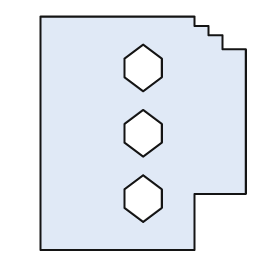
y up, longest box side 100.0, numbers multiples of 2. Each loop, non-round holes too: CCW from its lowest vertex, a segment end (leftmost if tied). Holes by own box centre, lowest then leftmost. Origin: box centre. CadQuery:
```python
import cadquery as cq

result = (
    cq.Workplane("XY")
    .moveTo(-44.0, -50.0)
    .lineTo(22.0, -50.0)
    .lineTo(22.0, -26.0)
    .lineTo(44.0, -26.0)
    .lineTo(44.0, 36.0)
    .lineTo(34.0, 36.0)
    .lineTo(34.0, 42.0)
    .lineTo(28.0, 42.0)
    .lineTo(28.0, 46.0)
    .lineTo(22.0, 46.0)
    .lineTo(22.0, 50.0)
    .lineTo(-44.0, 50.0)
    .close()
    .moveTo(0.0, -38.0)
    .lineTo(8.0, -32.0)
    .lineTo(8.0, -24.0)
    .lineTo(0.0, -18.0)
    .lineTo(-8.0, -24.0)
    .lineTo(-8.0, -32.0)
    .close()
    .moveTo(0.0, -10.0)
    .lineTo(8.0, -4.0)
    .lineTo(8.0, 4.0)
    .lineTo(0.0, 10.0)
    .lineTo(-8.0, 4.0)
    .lineTo(-8.0, -4.0)
    .close()
    .moveTo(0.0, 18.0)
    .lineTo(8.0, 24.0)
    .lineTo(8.0, 32.0)
    .lineTo(0.0, 38.0)
    .lineTo(-8.0, 32.0)
    .lineTo(-8.0, 24.0)
    .close()
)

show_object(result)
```